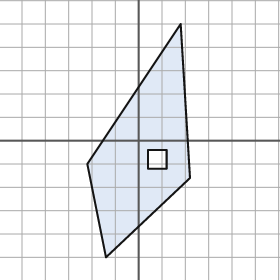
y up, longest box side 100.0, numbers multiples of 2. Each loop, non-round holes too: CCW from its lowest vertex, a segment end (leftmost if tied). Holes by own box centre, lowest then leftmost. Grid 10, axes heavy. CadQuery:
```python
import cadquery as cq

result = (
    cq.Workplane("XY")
    .moveTo(-14.0, -50.0)
    .lineTo(22.0, -16.0)
    .lineTo(18.0, 50.0)
    .lineTo(-22.0, -10.0)
    .close()
    .moveTo(4.0, -12.0)
    .lineTo(12.0, -12.0)
    .lineTo(12.0, -4.0)
    .lineTo(4.0, -4.0)
    .close()
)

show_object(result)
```